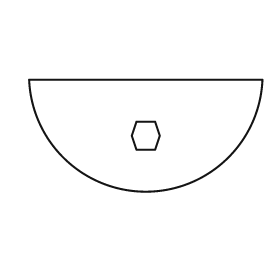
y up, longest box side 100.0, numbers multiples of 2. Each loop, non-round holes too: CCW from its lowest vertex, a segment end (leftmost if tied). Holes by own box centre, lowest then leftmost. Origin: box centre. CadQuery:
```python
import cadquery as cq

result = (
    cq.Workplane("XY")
    .moveTo(-50.0, 24.0)
    .threePointArc((0.0, -24.0), (50.0, 24.0))
    .close()
    .moveTo(-4.0, -6.0)
    .lineTo(4.0, -6.0)
    .lineTo(6.0, 0.0)
    .lineTo(4.0, 6.0)
    .lineTo(-4.0, 6.0)
    .lineTo(-6.0, 0.0)
    .close()
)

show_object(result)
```